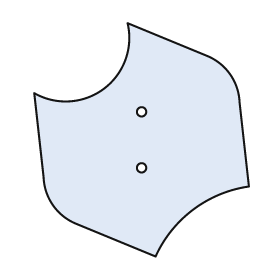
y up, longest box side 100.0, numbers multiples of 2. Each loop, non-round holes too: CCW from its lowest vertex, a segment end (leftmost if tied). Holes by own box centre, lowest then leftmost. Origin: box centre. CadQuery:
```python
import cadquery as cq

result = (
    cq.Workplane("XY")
    .moveTo(6.0, -50.0)
    .threePointArc((22.0, -30.0), (46.0, -20.0))
    .lineTo(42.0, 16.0)
    .threePointArc((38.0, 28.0), (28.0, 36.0))
    .lineTo(-6.0, 50.0)
    .threePointArc((-16.0, 22.0), (-46.0, 20.0))
    .lineTo(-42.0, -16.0)
    .threePointArc((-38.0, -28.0), (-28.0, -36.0))
    .close()
    .moveTo(0.0, -12.0)
    .circle(2.0)
    .moveTo(0.0, 12.0)
    .circle(2.0)
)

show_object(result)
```